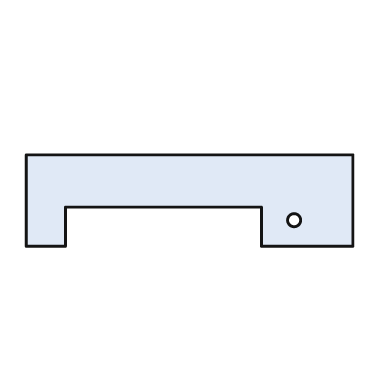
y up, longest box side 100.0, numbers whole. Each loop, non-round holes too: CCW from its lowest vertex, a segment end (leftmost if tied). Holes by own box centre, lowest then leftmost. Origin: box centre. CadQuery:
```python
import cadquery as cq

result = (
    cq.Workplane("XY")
    .moveTo(-50.0, -14.0)
    .lineTo(-38.0, -14.0)
    .lineTo(-38.0, -2.0)
    .lineTo(22.0, -2.0)
    .lineTo(22.0, -14.0)
    .lineTo(50.0, -14.0)
    .lineTo(50.0, 14.0)
    .lineTo(-50.0, 14.0)
    .close()
    .moveTo(32.0, -6.0)
    .circle(2.0)
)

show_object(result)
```